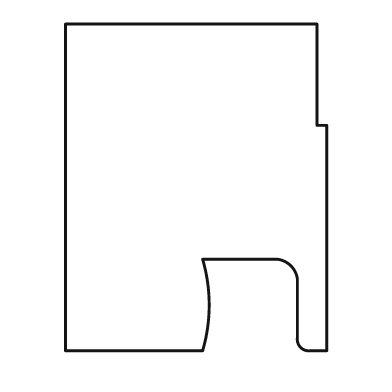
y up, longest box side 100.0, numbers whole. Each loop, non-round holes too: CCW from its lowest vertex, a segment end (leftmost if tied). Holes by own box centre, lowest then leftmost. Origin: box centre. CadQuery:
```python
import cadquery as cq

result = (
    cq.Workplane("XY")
    .moveTo(-40.0, -50.0)
    .lineTo(2.0, -50.0)
    .threePointArc((4.0, -36.0), (2.0, -22.0))
    .lineTo(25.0, -22.0)
    .threePointArc((29.0, -24.0), (31.0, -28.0))
    .lineTo(31.0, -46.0)
    .threePointArc((32.0, -49.0), (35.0, -50.0))
    .lineTo(40.0, -50.0)
    .lineTo(40.0, 19.0)
    .lineTo(37.0, 19.0)
    .lineTo(37.0, 50.0)
    .lineTo(-40.0, 50.0)
    .close()
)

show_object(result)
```